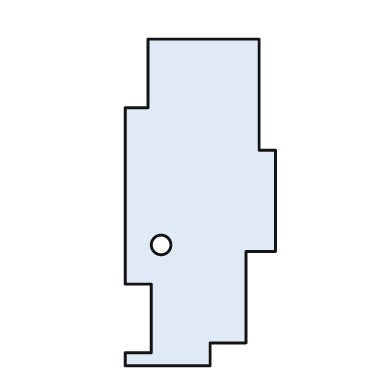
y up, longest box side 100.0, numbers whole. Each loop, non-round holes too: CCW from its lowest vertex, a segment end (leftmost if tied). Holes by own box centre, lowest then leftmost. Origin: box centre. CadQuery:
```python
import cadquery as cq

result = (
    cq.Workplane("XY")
    .moveTo(-23.0, -50.0)
    .lineTo(3.0, -50.0)
    .lineTo(3.0, -43.0)
    .lineTo(14.0, -43.0)
    .lineTo(14.0, -15.0)
    .lineTo(23.0, -15.0)
    .lineTo(23.0, 16.0)
    .lineTo(18.0, 16.0)
    .lineTo(18.0, 50.0)
    .lineTo(-16.0, 50.0)
    .lineTo(-16.0, 29.0)
    .lineTo(-23.0, 29.0)
    .lineTo(-23.0, -25.0)
    .lineTo(-15.0, -25.0)
    .lineTo(-15.0, -46.0)
    .lineTo(-23.0, -46.0)
    .close()
    .moveTo(-12.0, -13.0)
    .circle(3.0)
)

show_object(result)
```